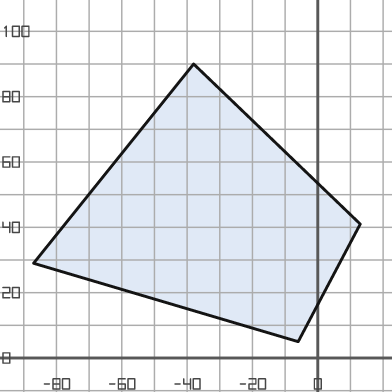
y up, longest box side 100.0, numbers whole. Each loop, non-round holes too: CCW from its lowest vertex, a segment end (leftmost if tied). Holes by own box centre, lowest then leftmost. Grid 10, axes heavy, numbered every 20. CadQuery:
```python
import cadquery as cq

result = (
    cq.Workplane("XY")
    .moveTo(-6.0, 5.0)
    .lineTo(13.0, 41.0)
    .lineTo(-38.0, 90.0)
    .lineTo(-87.0, 29.0)
    .close()
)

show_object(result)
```